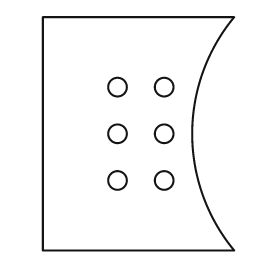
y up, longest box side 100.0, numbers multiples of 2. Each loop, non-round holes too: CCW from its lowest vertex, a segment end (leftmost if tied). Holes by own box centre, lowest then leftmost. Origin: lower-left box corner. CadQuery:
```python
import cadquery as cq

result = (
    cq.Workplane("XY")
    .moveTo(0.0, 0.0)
    .lineTo(82.0, 0.0)
    .threePointArc((64.0, 50.0), (82.0, 100.0))
    .lineTo(0.0, 100.0)
    .close()
    .moveTo(32.0, 30.0)
    .circle(4.0)
    .moveTo(52.0, 30.0)
    .circle(4.0)
    .moveTo(32.0, 50.0)
    .circle(4.0)
    .moveTo(52.0, 50.0)
    .circle(4.0)
    .moveTo(32.0, 70.0)
    .circle(4.0)
    .moveTo(52.0, 70.0)
    .circle(4.0)
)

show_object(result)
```